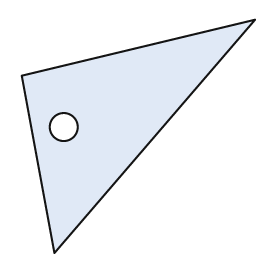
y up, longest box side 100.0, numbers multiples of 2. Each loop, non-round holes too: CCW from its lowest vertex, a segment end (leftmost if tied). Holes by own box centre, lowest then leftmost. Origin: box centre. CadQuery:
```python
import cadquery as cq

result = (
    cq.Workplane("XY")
    .moveTo(-36.0, -50.0)
    .lineTo(50.0, 50.0)
    .lineTo(-50.0, 26.0)
    .close()
    .moveTo(-32.0, 4.0)
    .circle(6.0)
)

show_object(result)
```